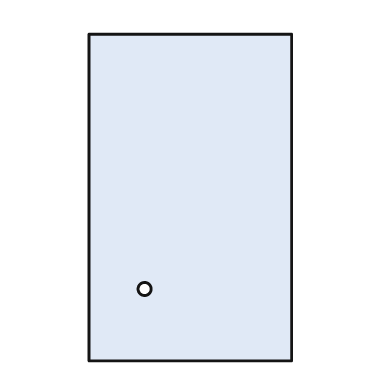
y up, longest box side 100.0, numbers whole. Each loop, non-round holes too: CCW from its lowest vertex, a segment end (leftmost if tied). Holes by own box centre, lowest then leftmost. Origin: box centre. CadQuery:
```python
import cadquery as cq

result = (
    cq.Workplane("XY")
    .moveTo(-31.0, -50.0)
    .lineTo(31.0, -50.0)
    .lineTo(31.0, 50.0)
    .lineTo(-31.0, 50.0)
    .close()
    .moveTo(-14.0, -28.0)
    .circle(2.0)
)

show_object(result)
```